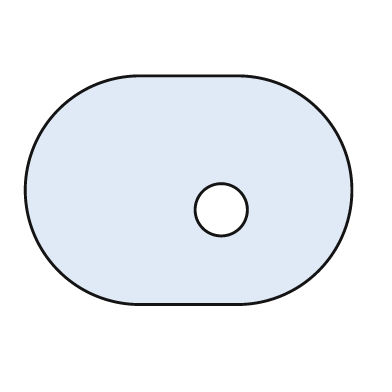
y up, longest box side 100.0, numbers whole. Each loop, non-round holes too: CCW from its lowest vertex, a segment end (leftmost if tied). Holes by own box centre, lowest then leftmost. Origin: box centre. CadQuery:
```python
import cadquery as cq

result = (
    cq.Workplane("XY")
    .moveTo(-15.0, -35.0)
    .lineTo(15.0, -35.0)
    .threePointArc((50.0, 0.0), (15.0, 35.0))
    .lineTo(-15.0, 35.0)
    .threePointArc((-50.0, 0.0), (-15.0, -35.0))
    .close()
    .moveTo(10.0, -6.0)
    .circle(8.0)
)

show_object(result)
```